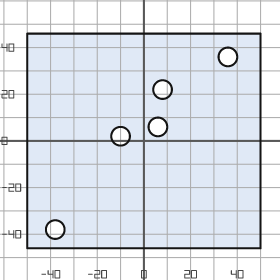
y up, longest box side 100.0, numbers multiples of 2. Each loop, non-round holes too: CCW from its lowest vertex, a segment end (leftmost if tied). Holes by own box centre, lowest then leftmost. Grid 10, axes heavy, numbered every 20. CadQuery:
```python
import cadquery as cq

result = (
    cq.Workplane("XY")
    .moveTo(-50.0, -46.0)
    .lineTo(50.0, -46.0)
    .lineTo(50.0, 46.0)
    .lineTo(-50.0, 46.0)
    .close()
    .moveTo(-38.0, -38.0)
    .circle(4.0)
    .moveTo(-10.0, 2.0)
    .circle(4.0)
    .moveTo(6.0, 6.0)
    .circle(4.0)
    .moveTo(8.0, 22.0)
    .circle(4.0)
    .moveTo(36.0, 36.0)
    .circle(4.0)
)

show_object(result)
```